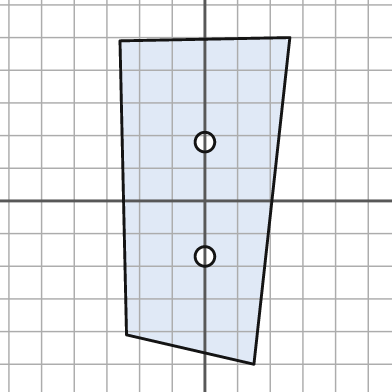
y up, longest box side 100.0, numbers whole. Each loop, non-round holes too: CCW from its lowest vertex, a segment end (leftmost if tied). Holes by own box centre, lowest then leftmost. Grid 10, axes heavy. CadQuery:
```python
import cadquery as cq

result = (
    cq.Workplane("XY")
    .moveTo(15.0, -50.0)
    .lineTo(26.0, 50.0)
    .lineTo(-26.0, 49.0)
    .lineTo(-24.0, -41.0)
    .close()
    .moveTo(0.0, -17.0)
    .circle(3.0)
    .moveTo(0.0, 18.0)
    .circle(3.0)
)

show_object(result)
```